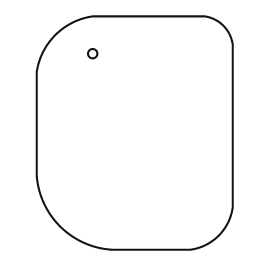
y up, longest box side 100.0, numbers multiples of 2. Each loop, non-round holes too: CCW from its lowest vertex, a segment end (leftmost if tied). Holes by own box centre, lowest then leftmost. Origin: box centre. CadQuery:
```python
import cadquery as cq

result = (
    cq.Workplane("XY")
    .moveTo(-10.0, -50.0)
    .lineTo(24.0, -50.0)
    .threePointArc((36.0, -44.0), (42.0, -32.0))
    .lineTo(42.0, 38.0)
    .threePointArc((38.0, 46.0), (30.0, 50.0))
    .lineTo(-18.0, 50.0)
    .threePointArc((-34.0, 42.0), (-42.0, 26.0))
    .lineTo(-42.0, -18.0)
    .threePointArc((-32.0, -40.0), (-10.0, -50.0))
    .close()
    .moveTo(-18.0, 34.0)
    .circle(2.0)
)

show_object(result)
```